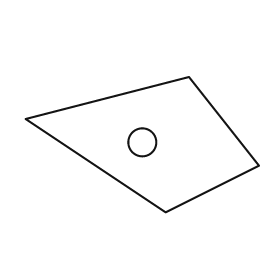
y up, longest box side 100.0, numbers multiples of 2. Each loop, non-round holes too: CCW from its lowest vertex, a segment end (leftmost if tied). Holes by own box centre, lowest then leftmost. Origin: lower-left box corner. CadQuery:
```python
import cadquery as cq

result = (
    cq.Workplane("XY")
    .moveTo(60.0, 0.0)
    .lineTo(100.0, 20.0)
    .lineTo(70.0, 58.0)
    .lineTo(0.0, 40.0)
    .close()
    .moveTo(50.0, 30.0)
    .circle(6.0)
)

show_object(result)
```